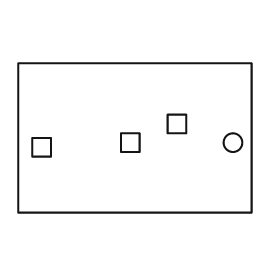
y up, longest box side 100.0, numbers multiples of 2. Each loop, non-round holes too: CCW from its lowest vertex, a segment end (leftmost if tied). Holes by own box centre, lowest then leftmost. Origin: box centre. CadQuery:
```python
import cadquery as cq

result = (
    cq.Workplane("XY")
    .moveTo(-50.0, -32.0)
    .lineTo(50.0, -32.0)
    .lineTo(50.0, 32.0)
    .lineTo(-50.0, 32.0)
    .close()
    .moveTo(-44.0, -8.0)
    .lineTo(-36.0, -8.0)
    .lineTo(-36.0, 0.0)
    .lineTo(-44.0, 0.0)
    .close()
    .moveTo(-6.0, -6.0)
    .lineTo(2.0, -6.0)
    .lineTo(2.0, 2.0)
    .lineTo(-6.0, 2.0)
    .close()
    .moveTo(42.0, -2.0)
    .circle(4.0)
    .moveTo(14.0, 2.0)
    .lineTo(22.0, 2.0)
    .lineTo(22.0, 10.0)
    .lineTo(14.0, 10.0)
    .close()
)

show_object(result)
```